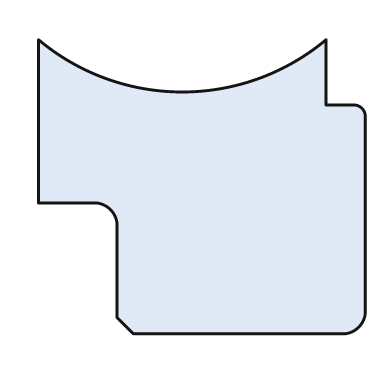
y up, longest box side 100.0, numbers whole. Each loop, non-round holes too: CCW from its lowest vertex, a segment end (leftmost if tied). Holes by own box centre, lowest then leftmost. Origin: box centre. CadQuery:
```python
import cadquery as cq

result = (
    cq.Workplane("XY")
    .moveTo(-21.0, -45.0)
    .lineTo(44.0, -45.0)
    .threePointArc((48.0, -43.0), (50.0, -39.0))
    .lineTo(50.0, 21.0)
    .threePointArc((49.0, 24.0), (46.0, 25.0))
    .lineTo(38.0, 25.0)
    .lineTo(38.0, 45.0)
    .threePointArc((-6.0, 29.0), (-50.0, 45.0))
    .lineTo(-50.0, -5.0)
    .lineTo(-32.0, -5.0)
    .threePointArc((-28.0, -7.0), (-26.0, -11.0))
    .lineTo(-26.0, -40.0)
    .close()
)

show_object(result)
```